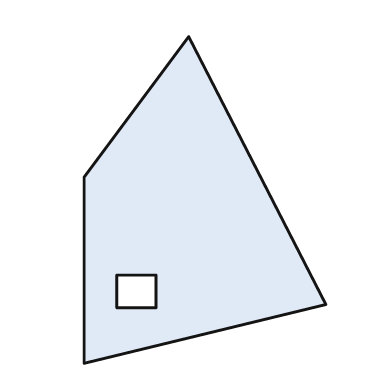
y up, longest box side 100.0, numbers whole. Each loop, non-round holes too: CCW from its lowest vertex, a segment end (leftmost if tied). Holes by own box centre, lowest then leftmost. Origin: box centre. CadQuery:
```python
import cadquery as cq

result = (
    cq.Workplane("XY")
    .moveTo(-37.0, -50.0)
    .lineTo(37.0, -32.0)
    .lineTo(-5.0, 50.0)
    .lineTo(-37.0, 7.0)
    .close()
    .moveTo(-27.0, -33.0)
    .lineTo(-15.0, -33.0)
    .lineTo(-15.0, -23.0)
    .lineTo(-27.0, -23.0)
    .close()
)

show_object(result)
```